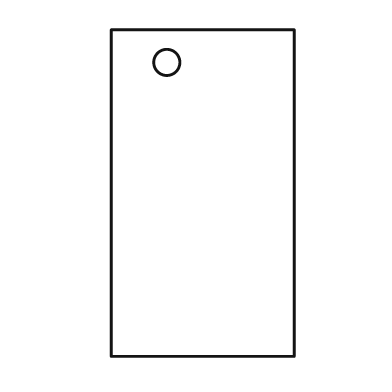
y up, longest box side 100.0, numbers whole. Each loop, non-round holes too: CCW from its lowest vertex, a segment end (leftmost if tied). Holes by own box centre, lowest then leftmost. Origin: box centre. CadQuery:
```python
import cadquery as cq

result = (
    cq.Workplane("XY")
    .moveTo(-28.0, -50.0)
    .lineTo(28.0, -50.0)
    .lineTo(28.0, 50.0)
    .lineTo(-28.0, 50.0)
    .close()
    .moveTo(-11.0, 40.0)
    .circle(4.0)
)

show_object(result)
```